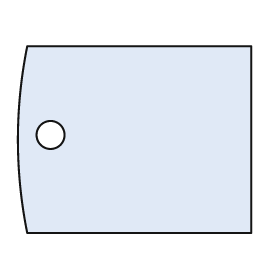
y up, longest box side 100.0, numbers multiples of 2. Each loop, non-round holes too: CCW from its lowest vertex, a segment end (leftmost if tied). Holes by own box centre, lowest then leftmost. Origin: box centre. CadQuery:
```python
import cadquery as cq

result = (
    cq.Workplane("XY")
    .moveTo(-46.0, -40.0)
    .lineTo(50.0, -40.0)
    .lineTo(50.0, 40.0)
    .lineTo(-46.0, 40.0)
    .threePointArc((-50.0, 0.0), (-46.0, -40.0))
    .close()
    .moveTo(-36.0, 2.0)
    .circle(6.0)
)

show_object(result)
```